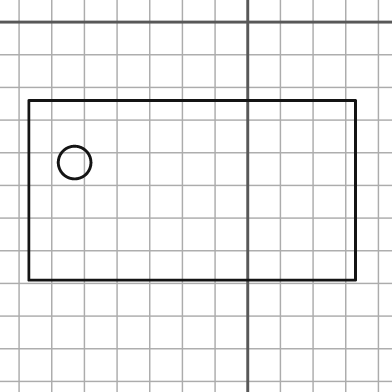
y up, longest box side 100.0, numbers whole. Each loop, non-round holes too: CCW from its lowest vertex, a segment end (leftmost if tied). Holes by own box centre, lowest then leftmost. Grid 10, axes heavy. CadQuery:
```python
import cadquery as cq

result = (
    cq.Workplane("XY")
    .moveTo(-67.0, -79.0)
    .lineTo(33.0, -79.0)
    .lineTo(33.0, -24.0)
    .lineTo(-67.0, -24.0)
    .close()
    .moveTo(-53.0, -43.0)
    .circle(5.0)
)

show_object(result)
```